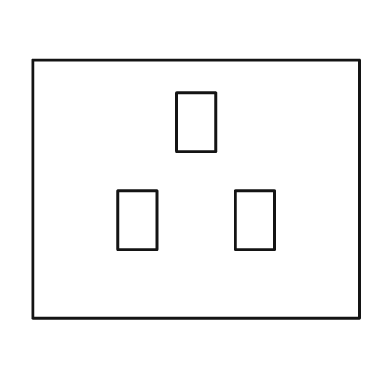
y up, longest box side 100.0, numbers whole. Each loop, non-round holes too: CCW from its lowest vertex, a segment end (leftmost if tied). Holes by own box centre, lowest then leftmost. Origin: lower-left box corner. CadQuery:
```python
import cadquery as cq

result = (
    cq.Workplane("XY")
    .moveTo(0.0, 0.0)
    .lineTo(100.0, 0.0)
    .lineTo(100.0, 79.0)
    .lineTo(0.0, 79.0)
    .close()
    .moveTo(26.0, 21.0)
    .lineTo(38.0, 21.0)
    .lineTo(38.0, 39.0)
    .lineTo(26.0, 39.0)
    .close()
    .moveTo(62.0, 21.0)
    .lineTo(74.0, 21.0)
    .lineTo(74.0, 39.0)
    .lineTo(62.0, 39.0)
    .close()
    .moveTo(44.0, 51.0)
    .lineTo(56.0, 51.0)
    .lineTo(56.0, 69.0)
    .lineTo(44.0, 69.0)
    .close()
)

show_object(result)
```